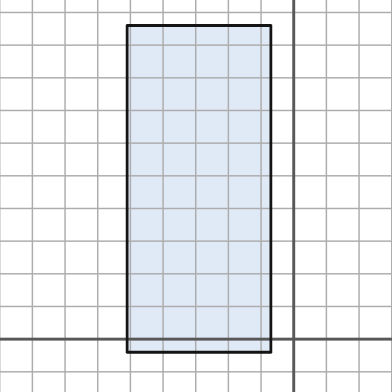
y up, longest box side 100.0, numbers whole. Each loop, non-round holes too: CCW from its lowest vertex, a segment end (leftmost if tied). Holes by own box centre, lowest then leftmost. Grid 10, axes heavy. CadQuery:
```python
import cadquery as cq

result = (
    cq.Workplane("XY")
    .moveTo(-51.0, -4.0)
    .lineTo(-7.0, -4.0)
    .lineTo(-7.0, 96.0)
    .lineTo(-51.0, 96.0)
    .close()
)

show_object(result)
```